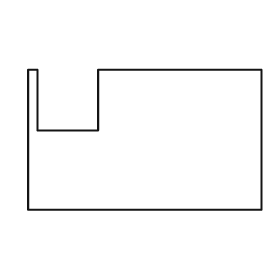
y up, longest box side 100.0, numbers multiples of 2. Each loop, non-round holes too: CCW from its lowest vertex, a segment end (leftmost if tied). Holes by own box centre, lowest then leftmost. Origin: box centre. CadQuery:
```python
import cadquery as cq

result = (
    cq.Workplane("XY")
    .moveTo(-50.0, -30.0)
    .lineTo(50.0, -30.0)
    .lineTo(50.0, 30.0)
    .lineTo(-20.0, 30.0)
    .lineTo(-20.0, 4.0)
    .lineTo(-46.0, 4.0)
    .lineTo(-46.0, 30.0)
    .lineTo(-50.0, 30.0)
    .close()
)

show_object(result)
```